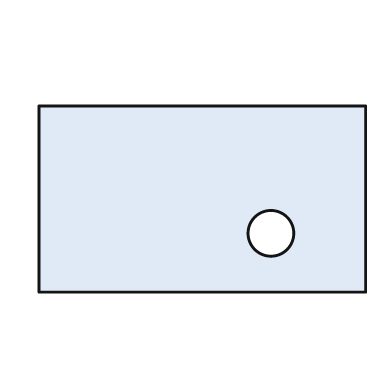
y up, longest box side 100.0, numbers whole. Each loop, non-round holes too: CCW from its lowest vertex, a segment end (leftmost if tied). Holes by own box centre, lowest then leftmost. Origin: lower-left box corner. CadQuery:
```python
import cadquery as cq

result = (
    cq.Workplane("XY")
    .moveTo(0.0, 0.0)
    .lineTo(100.0, 0.0)
    .lineTo(100.0, 57.0)
    .lineTo(0.0, 57.0)
    .close()
    .moveTo(71.0, 18.0)
    .circle(7.0)
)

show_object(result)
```